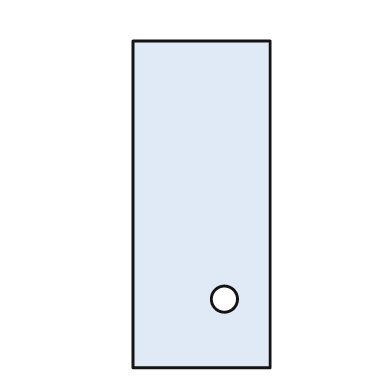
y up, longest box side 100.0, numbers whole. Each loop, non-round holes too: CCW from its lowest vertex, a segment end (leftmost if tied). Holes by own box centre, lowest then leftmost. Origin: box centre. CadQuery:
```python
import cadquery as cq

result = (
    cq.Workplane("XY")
    .moveTo(-21.0, -50.0)
    .lineTo(21.0, -50.0)
    .lineTo(21.0, 50.0)
    .lineTo(-21.0, 50.0)
    .close()
    .moveTo(7.0, -29.0)
    .circle(4.0)
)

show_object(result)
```